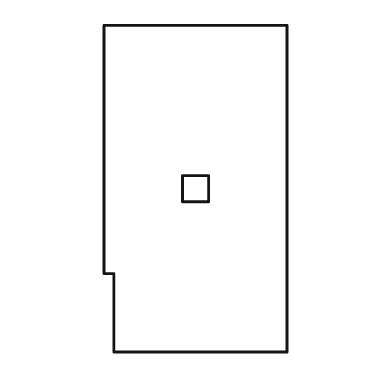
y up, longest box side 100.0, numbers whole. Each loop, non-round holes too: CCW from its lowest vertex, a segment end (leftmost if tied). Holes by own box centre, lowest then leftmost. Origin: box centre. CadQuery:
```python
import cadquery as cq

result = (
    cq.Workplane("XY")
    .moveTo(-25.0, -50.0)
    .lineTo(28.0, -50.0)
    .lineTo(28.0, 50.0)
    .lineTo(-28.0, 50.0)
    .lineTo(-28.0, -26.0)
    .lineTo(-25.0, -26.0)
    .close()
    .moveTo(-4.0, -4.0)
    .lineTo(4.0, -4.0)
    .lineTo(4.0, 4.0)
    .lineTo(-4.0, 4.0)
    .close()
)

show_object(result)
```